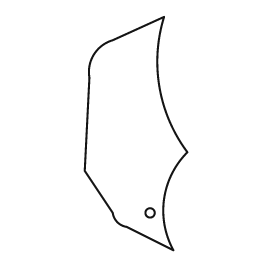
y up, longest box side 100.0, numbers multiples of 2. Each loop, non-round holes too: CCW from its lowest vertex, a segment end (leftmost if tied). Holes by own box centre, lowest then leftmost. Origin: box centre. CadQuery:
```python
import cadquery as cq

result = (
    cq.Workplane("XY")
    .moveTo(16.0, -50.0)
    .threePointArc((12.0, -28.0), (22.0, -8.0))
    .threePointArc((10.0, 20.0), (12.0, 50.0))
    .lineTo(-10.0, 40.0)
    .threePointArc((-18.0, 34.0), (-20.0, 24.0))
    .lineTo(-22.0, -16.0)
    .lineTo(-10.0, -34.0)
    .threePointArc((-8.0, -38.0), (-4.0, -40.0))
    .close()
    .moveTo(6.0, -34.0)
    .circle(2.0)
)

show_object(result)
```